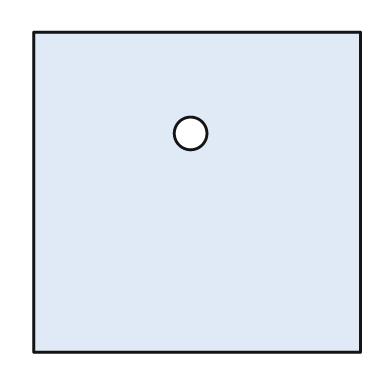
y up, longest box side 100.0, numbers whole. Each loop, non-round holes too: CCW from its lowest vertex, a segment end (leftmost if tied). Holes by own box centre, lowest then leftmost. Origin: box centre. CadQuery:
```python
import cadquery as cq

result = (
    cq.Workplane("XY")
    .moveTo(-50.0, -49.0)
    .lineTo(50.0, -49.0)
    .lineTo(50.0, 49.0)
    .lineTo(-50.0, 49.0)
    .close()
    .moveTo(-2.0, 18.0)
    .circle(5.0)
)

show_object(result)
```